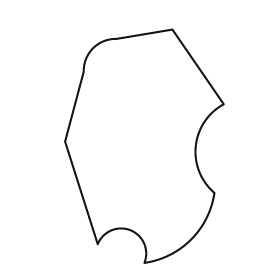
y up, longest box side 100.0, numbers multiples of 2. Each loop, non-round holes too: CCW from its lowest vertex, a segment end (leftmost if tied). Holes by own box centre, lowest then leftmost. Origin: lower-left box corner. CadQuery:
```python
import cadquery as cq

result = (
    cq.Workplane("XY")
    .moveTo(34.0, 0.0)
    .threePointArc((54.0, 10.0), (64.0, 30.0))
    .threePointArc((56.0, 50.0), (68.0, 68.0))
    .lineTo(46.0, 100.0)
    .lineTo(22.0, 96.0)
    .threePointArc((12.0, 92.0), (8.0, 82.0))
    .lineTo(0.0, 52.0)
    .lineTo(14.0, 8.0)
    .threePointArc((28.0, 14.0), (34.0, 0.0))
    .close()
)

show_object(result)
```